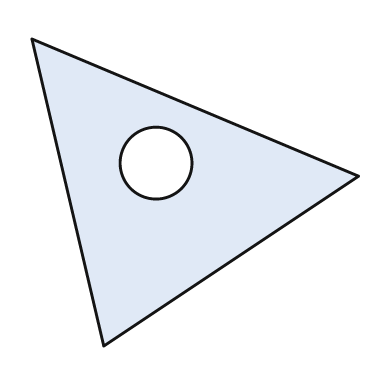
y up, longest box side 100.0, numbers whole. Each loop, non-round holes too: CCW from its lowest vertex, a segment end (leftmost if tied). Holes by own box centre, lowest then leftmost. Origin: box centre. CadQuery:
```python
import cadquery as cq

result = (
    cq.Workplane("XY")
    .moveTo(-28.0, -47.0)
    .lineTo(50.0, 5.0)
    .lineTo(-50.0, 47.0)
    .close()
    .moveTo(-12.0, 9.0)
    .circle(11.0)
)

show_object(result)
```